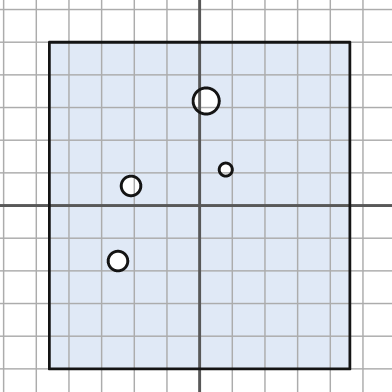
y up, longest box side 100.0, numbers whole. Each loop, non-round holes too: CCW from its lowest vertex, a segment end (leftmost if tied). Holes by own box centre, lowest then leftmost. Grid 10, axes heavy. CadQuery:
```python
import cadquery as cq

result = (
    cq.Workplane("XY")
    .moveTo(-46.0, -50.0)
    .lineTo(46.0, -50.0)
    .lineTo(46.0, 50.0)
    .lineTo(-46.0, 50.0)
    .close()
    .moveTo(-25.0, -17.0)
    .circle(3.0)
    .moveTo(-21.0, 6.0)
    .circle(3.0)
    .moveTo(8.0, 11.0)
    .circle(2.0)
    .moveTo(2.0, 32.0)
    .circle(4.0)
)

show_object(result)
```